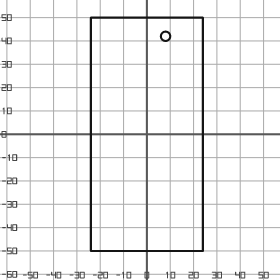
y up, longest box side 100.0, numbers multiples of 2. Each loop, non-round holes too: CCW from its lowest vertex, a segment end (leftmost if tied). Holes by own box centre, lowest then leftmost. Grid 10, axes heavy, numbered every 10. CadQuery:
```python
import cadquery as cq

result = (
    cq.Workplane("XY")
    .moveTo(-24.0, -50.0)
    .lineTo(24.0, -50.0)
    .lineTo(24.0, 50.0)
    .lineTo(-24.0, 50.0)
    .close()
    .moveTo(8.0, 42.0)
    .circle(2.0)
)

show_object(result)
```